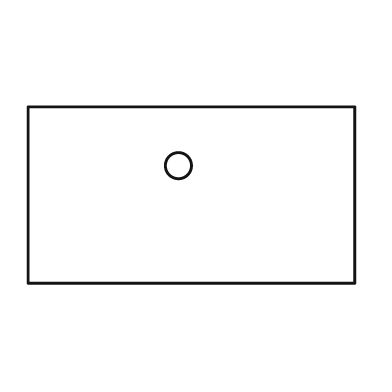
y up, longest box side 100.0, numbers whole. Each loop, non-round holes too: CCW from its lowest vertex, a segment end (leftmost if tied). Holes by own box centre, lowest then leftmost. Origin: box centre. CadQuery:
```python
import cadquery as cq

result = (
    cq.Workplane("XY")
    .moveTo(-50.0, -27.0)
    .lineTo(50.0, -27.0)
    .lineTo(50.0, 27.0)
    .lineTo(-50.0, 27.0)
    .close()
    .moveTo(-4.0, 9.0)
    .circle(4.0)
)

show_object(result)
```